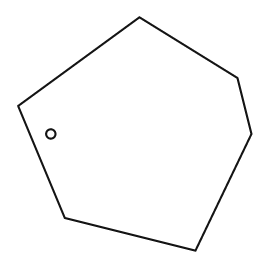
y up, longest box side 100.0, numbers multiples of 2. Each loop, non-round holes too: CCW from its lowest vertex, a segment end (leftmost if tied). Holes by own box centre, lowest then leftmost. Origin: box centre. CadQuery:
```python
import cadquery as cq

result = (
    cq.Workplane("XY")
    .moveTo(26.0, -50.0)
    .lineTo(50.0, 0.0)
    .lineTo(44.0, 24.0)
    .lineTo(2.0, 50.0)
    .lineTo(-50.0, 12.0)
    .lineTo(-30.0, -36.0)
    .close()
    .moveTo(-36.0, 0.0)
    .circle(2.0)
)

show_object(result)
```